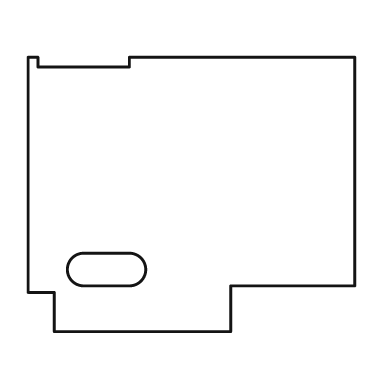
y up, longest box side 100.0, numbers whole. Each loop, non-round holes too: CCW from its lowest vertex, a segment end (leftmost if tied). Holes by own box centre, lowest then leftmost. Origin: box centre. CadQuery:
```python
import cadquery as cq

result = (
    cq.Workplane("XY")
    .moveTo(-42.0, -42.0)
    .lineTo(12.0, -42.0)
    .lineTo(12.0, -28.0)
    .lineTo(50.0, -28.0)
    .lineTo(50.0, 42.0)
    .lineTo(-19.0, 42.0)
    .lineTo(-19.0, 39.0)
    .lineTo(-47.0, 39.0)
    .lineTo(-47.0, 42.0)
    .lineTo(-50.0, 42.0)
    .lineTo(-50.0, -30.0)
    .lineTo(-42.0, -30.0)
    .close()
    .moveTo(-33.0, -28.0)
    .lineTo(-19.0, -28.0)
    .threePointArc((-14.0, -23.0), (-19.0, -18.0))
    .lineTo(-33.0, -18.0)
    .threePointArc((-38.0, -23.0), (-33.0, -28.0))
    .close()
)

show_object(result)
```